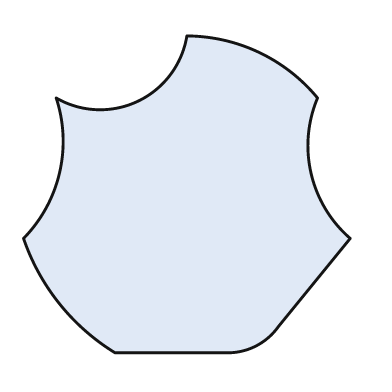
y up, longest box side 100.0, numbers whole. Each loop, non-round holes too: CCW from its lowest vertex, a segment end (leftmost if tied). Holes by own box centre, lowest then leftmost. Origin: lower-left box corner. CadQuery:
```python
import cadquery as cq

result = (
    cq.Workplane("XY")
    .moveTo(28.0, 0.0)
    .lineTo(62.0, 0.0)
    .threePointArc((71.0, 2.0), (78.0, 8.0))
    .lineTo(100.0, 35.0)
    .threePointArc((88.0, 55.0), (90.0, 78.0))
    .threePointArc((72.0, 92.0), (50.0, 97.0))
    .threePointArc((35.0, 77.0), (10.0, 78.0))
    .threePointArc((11.0, 55.0), (0.0, 35.0))
    .threePointArc((11.0, 15.0), (28.0, 0.0))
    .close()
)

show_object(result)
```